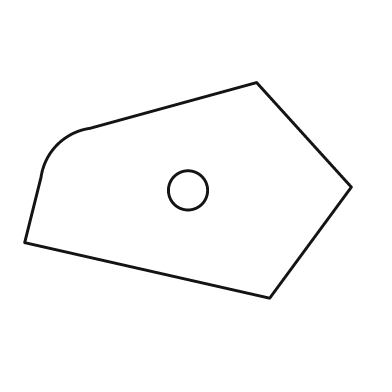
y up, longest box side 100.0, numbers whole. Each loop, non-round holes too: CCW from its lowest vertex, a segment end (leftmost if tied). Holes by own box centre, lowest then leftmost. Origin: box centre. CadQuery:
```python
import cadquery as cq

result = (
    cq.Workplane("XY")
    .moveTo(25.0, -33.0)
    .lineTo(50.0, 1.0)
    .lineTo(21.0, 33.0)
    .lineTo(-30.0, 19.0)
    .threePointArc((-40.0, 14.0), (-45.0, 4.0))
    .lineTo(-50.0, -16.0)
    .close()
    .moveTo(0.0, 0.0)
    .circle(6.0)
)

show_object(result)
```